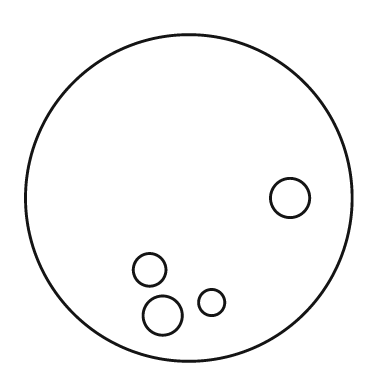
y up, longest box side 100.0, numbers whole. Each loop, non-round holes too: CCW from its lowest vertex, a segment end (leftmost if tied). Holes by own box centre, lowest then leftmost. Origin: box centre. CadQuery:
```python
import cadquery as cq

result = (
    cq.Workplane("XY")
    .moveTo(0.0, 0.0)
    .circle(50.0)
    .moveTo(-8.0, -36.0)
    .circle(6.0)
    .moveTo(7.0, -32.0)
    .circle(4.0)
    .moveTo(-12.0, -22.0)
    .circle(5.0)
    .moveTo(31.0, 0.0)
    .circle(6.0)
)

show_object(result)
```